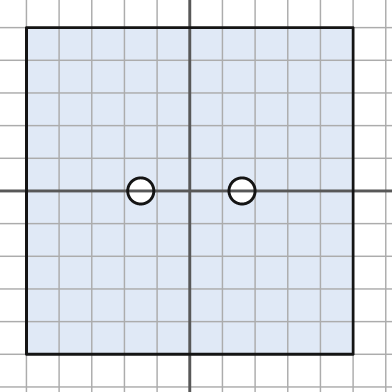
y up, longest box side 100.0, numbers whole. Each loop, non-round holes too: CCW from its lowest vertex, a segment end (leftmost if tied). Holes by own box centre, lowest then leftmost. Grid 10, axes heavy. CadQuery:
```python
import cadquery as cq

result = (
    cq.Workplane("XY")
    .moveTo(-50.0, -50.0)
    .lineTo(50.0, -50.0)
    .lineTo(50.0, 50.0)
    .lineTo(-50.0, 50.0)
    .close()
    .moveTo(-15.0, 0.0)
    .circle(4.0)
    .moveTo(16.0, 0.0)
    .circle(4.0)
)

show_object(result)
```